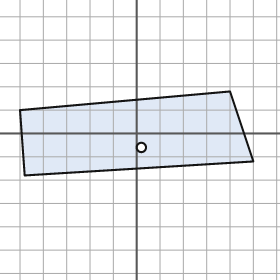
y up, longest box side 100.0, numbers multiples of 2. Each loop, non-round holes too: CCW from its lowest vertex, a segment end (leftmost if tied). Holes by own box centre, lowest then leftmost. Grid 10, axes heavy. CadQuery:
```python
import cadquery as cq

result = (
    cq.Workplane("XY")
    .moveTo(-48.0, -18.0)
    .lineTo(50.0, -12.0)
    .lineTo(40.0, 18.0)
    .lineTo(-50.0, 10.0)
    .close()
    .moveTo(2.0, -6.0)
    .circle(2.0)
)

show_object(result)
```